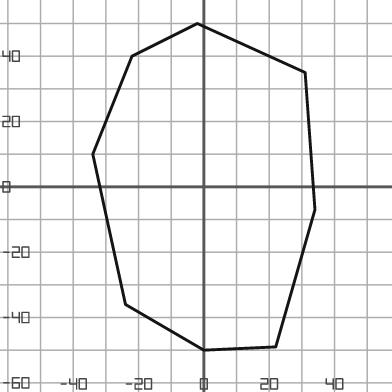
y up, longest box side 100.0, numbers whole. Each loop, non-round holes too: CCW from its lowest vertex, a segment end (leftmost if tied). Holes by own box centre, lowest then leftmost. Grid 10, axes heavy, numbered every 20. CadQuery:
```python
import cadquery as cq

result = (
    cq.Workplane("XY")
    .moveTo(0.0, -50.0)
    .lineTo(22.0, -49.0)
    .lineTo(34.0, -7.0)
    .lineTo(31.0, 35.0)
    .lineTo(-2.0, 50.0)
    .lineTo(-22.0, 40.0)
    .lineTo(-34.0, 10.0)
    .lineTo(-24.0, -36.0)
    .close()
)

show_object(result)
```